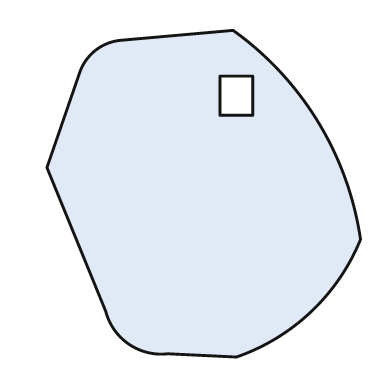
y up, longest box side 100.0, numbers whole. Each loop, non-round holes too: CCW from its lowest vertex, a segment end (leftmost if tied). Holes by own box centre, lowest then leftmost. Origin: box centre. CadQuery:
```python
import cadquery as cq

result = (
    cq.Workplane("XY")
    .moveTo(10.0, -50.0)
    .threePointArc((33.0, -36.0), (48.0, -14.0))
    .threePointArc((35.0, 22.0), (9.0, 50.0))
    .lineTo(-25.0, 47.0)
    .threePointArc((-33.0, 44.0), (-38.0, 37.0))
    .lineTo(-48.0, 8.0)
    .lineTo(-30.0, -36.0)
    .threePointArc((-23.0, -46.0), (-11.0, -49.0))
    .close()
    .moveTo(5.0, 24.0)
    .lineTo(15.0, 24.0)
    .lineTo(15.0, 36.0)
    .lineTo(5.0, 36.0)
    .close()
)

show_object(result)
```